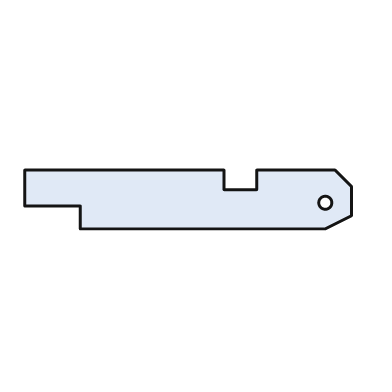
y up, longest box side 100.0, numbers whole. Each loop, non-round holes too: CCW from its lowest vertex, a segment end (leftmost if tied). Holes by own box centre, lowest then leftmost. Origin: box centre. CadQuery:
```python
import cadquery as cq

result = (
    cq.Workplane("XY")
    .moveTo(-33.0, -9.0)
    .lineTo(42.0, -9.0)
    .lineTo(50.0, -5.0)
    .lineTo(50.0, 4.0)
    .lineTo(45.0, 9.0)
    .lineTo(21.0, 9.0)
    .lineTo(21.0, 3.0)
    .lineTo(11.0, 3.0)
    .lineTo(11.0, 9.0)
    .lineTo(-50.0, 9.0)
    .lineTo(-50.0, -2.0)
    .lineTo(-33.0, -2.0)
    .close()
    .moveTo(42.0, -1.0)
    .circle(2.0)
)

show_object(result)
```